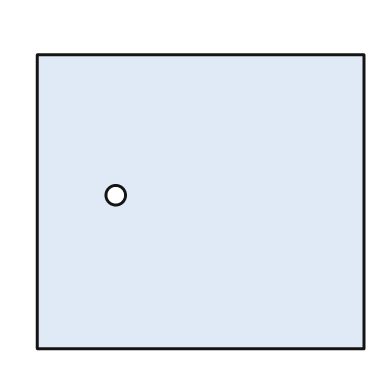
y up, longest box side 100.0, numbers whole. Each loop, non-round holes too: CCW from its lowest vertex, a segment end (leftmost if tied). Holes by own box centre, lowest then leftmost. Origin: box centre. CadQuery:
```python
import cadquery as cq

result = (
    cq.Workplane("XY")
    .moveTo(-50.0, -45.0)
    .lineTo(50.0, -45.0)
    .lineTo(50.0, 45.0)
    .lineTo(-50.0, 45.0)
    .close()
    .moveTo(-26.0, 2.0)
    .circle(3.0)
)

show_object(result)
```